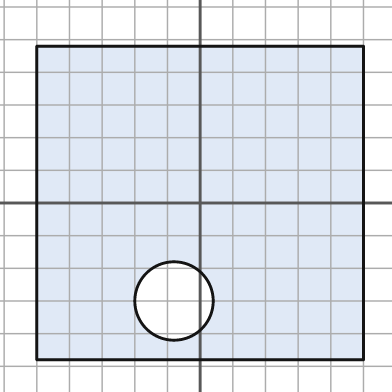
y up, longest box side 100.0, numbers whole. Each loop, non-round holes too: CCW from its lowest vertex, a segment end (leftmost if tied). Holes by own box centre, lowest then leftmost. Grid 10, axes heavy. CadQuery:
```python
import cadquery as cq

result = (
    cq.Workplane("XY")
    .moveTo(-50.0, -48.0)
    .lineTo(50.0, -48.0)
    .lineTo(50.0, 48.0)
    .lineTo(-50.0, 48.0)
    .close()
    .moveTo(-8.0, -30.0)
    .circle(12.0)
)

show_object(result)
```